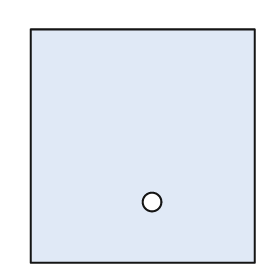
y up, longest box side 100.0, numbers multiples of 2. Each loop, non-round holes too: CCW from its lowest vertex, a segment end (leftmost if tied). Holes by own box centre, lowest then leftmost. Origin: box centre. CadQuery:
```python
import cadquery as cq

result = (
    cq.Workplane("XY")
    .moveTo(-48.0, -50.0)
    .lineTo(48.0, -50.0)
    .lineTo(48.0, 50.0)
    .lineTo(-48.0, 50.0)
    .close()
    .moveTo(4.0, -24.0)
    .circle(4.0)
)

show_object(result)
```